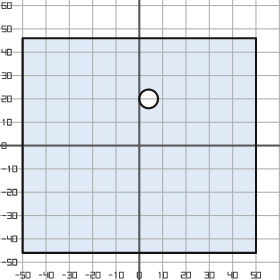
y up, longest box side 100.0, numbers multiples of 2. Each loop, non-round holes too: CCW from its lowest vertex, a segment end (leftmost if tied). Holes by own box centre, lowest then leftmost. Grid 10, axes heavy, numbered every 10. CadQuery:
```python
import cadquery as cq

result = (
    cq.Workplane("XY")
    .moveTo(-50.0, -46.0)
    .lineTo(50.0, -46.0)
    .lineTo(50.0, 46.0)
    .lineTo(-50.0, 46.0)
    .close()
    .moveTo(4.0, 20.0)
    .circle(4.0)
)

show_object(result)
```